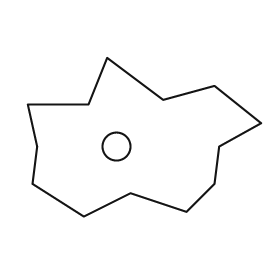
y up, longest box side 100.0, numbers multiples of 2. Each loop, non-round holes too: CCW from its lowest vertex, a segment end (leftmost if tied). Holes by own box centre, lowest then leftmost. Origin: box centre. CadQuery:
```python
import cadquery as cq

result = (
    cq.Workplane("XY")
    .moveTo(-26.0, -34.0)
    .lineTo(-6.0, -24.0)
    .lineTo(18.0, -32.0)
    .lineTo(30.0, -20.0)
    .lineTo(32.0, -4.0)
    .lineTo(50.0, 6.0)
    .lineTo(30.0, 22.0)
    .lineTo(8.0, 16.0)
    .lineTo(-16.0, 34.0)
    .lineTo(-24.0, 14.0)
    .lineTo(-50.0, 14.0)
    .lineTo(-46.0, -4.0)
    .lineTo(-48.0, -20.0)
    .close()
    .moveTo(-12.0, -4.0)
    .circle(6.0)
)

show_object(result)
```